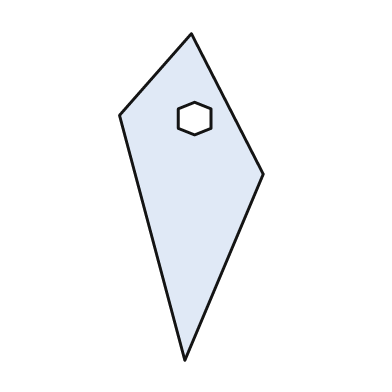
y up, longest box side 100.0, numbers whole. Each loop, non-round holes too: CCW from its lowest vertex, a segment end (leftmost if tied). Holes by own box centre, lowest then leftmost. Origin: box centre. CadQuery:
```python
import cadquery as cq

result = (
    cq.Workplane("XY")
    .moveTo(-2.0, -50.0)
    .lineTo(22.0, 7.0)
    .lineTo(0.0, 50.0)
    .lineTo(-22.0, 25.0)
    .close()
    .moveTo(1.0, 19.0)
    .lineTo(6.0, 21.0)
    .lineTo(6.0, 27.0)
    .lineTo(1.0, 29.0)
    .lineTo(-4.0, 27.0)
    .lineTo(-4.0, 21.0)
    .close()
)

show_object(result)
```